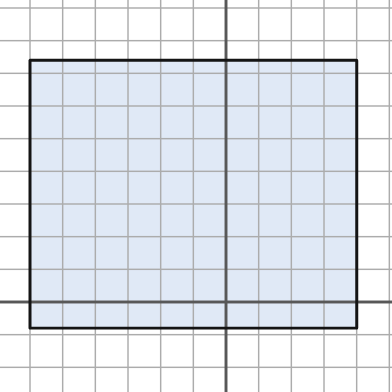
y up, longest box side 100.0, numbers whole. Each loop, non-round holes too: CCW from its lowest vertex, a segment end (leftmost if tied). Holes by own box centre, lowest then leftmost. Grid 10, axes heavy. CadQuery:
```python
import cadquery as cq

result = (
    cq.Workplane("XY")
    .moveTo(-60.0, -8.0)
    .lineTo(40.0, -8.0)
    .lineTo(40.0, 74.0)
    .lineTo(-60.0, 74.0)
    .close()
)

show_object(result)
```